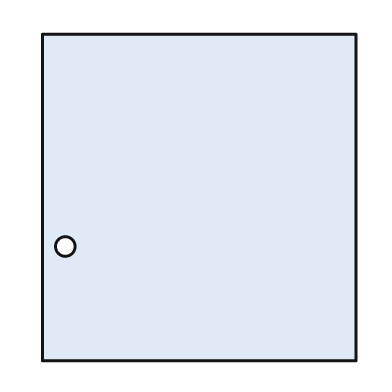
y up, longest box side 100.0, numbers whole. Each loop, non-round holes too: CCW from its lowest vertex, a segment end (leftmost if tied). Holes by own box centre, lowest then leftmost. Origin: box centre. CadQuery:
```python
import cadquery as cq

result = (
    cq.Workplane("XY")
    .moveTo(-48.0, -50.0)
    .lineTo(48.0, -50.0)
    .lineTo(48.0, 50.0)
    .lineTo(-48.0, 50.0)
    .close()
    .moveTo(-41.0, -15.0)
    .circle(3.0)
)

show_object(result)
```